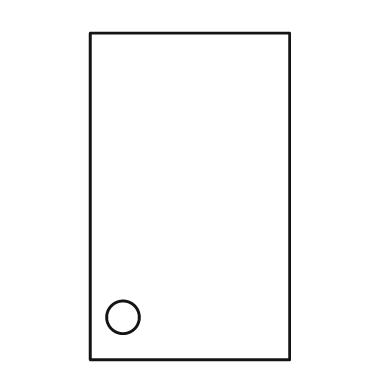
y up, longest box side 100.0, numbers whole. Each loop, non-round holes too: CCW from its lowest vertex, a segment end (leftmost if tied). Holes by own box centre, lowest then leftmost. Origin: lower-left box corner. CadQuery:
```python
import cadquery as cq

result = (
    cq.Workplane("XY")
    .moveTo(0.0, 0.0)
    .lineTo(61.0, 0.0)
    .lineTo(61.0, 100.0)
    .lineTo(0.0, 100.0)
    .close()
    .moveTo(10.0, 13.0)
    .circle(5.0)
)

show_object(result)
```